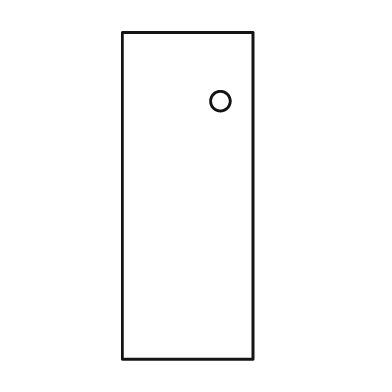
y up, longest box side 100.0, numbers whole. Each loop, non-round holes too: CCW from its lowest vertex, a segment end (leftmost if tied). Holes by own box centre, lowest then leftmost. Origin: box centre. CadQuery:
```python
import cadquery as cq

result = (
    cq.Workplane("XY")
    .moveTo(-20.0, -50.0)
    .lineTo(20.0, -50.0)
    .lineTo(20.0, 50.0)
    .lineTo(-20.0, 50.0)
    .close()
    .moveTo(10.0, 29.0)
    .circle(3.0)
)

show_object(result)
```